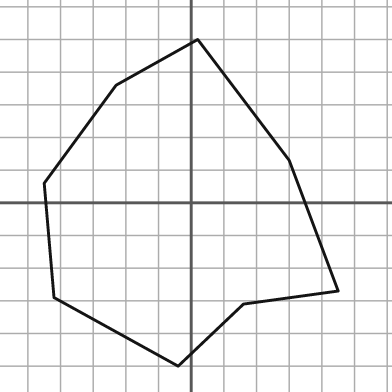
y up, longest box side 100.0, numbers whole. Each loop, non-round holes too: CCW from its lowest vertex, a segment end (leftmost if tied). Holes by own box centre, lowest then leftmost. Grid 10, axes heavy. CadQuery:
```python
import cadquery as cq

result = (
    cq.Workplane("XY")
    .moveTo(-4.0, -50.0)
    .lineTo(16.0, -31.0)
    .lineTo(45.0, -27.0)
    .lineTo(30.0, 13.0)
    .lineTo(2.0, 50.0)
    .lineTo(-23.0, 36.0)
    .lineTo(-45.0, 6.0)
    .lineTo(-42.0, -29.0)
    .close()
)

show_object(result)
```